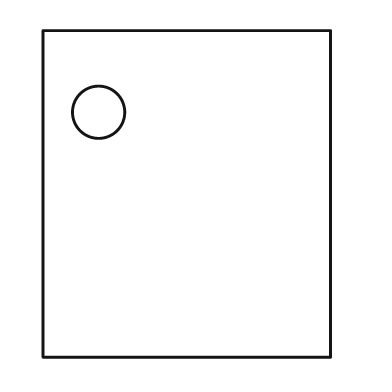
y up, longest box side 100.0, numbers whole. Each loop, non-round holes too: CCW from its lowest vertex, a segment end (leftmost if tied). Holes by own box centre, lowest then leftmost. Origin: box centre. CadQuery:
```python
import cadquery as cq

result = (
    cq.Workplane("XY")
    .moveTo(-44.0, -50.0)
    .lineTo(44.0, -50.0)
    .lineTo(44.0, 50.0)
    .lineTo(-44.0, 50.0)
    .close()
    .moveTo(-27.0, 25.0)
    .circle(8.0)
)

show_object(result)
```